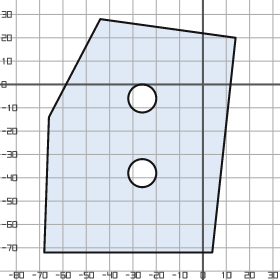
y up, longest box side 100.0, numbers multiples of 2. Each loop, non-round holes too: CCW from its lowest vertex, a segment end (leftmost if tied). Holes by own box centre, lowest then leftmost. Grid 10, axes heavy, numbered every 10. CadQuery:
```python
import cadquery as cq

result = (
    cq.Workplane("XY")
    .moveTo(-68.0, -72.0)
    .lineTo(4.0, -72.0)
    .lineTo(14.0, 20.0)
    .lineTo(-44.0, 28.0)
    .lineTo(-66.0, -14.0)
    .close()
    .moveTo(-26.0, -38.0)
    .circle(6.0)
    .moveTo(-26.0, -6.0)
    .circle(6.0)
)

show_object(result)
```